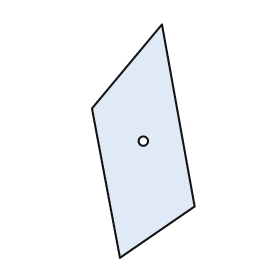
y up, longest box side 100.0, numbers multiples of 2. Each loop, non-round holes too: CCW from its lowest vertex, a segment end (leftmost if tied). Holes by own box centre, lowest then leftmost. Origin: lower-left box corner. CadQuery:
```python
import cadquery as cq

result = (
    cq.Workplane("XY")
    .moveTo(12.0, 0.0)
    .lineTo(44.0, 22.0)
    .lineTo(30.0, 100.0)
    .lineTo(0.0, 64.0)
    .close()
    .moveTo(22.0, 50.0)
    .circle(2.0)
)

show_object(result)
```